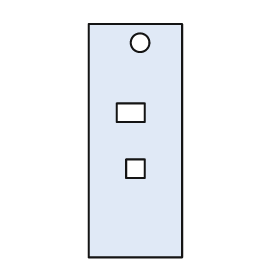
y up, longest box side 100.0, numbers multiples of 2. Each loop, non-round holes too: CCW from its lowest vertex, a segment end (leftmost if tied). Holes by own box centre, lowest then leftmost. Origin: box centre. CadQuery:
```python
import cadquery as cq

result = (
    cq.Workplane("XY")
    .moveTo(-20.0, -50.0)
    .lineTo(20.0, -50.0)
    .lineTo(20.0, 50.0)
    .lineTo(-20.0, 50.0)
    .close()
    .moveTo(-4.0, -16.0)
    .lineTo(4.0, -16.0)
    .lineTo(4.0, -8.0)
    .lineTo(-4.0, -8.0)
    .close()
    .moveTo(-8.0, 8.0)
    .lineTo(4.0, 8.0)
    .lineTo(4.0, 16.0)
    .lineTo(-8.0, 16.0)
    .close()
    .moveTo(2.0, 42.0)
    .circle(4.0)
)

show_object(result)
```